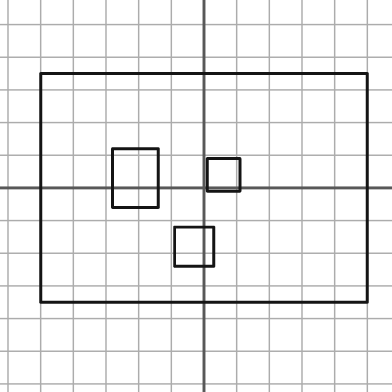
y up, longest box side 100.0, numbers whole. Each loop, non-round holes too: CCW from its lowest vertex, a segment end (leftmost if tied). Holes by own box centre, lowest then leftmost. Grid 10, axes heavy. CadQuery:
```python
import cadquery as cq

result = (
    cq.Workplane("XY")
    .moveTo(-50.0, -35.0)
    .lineTo(50.0, -35.0)
    .lineTo(50.0, 35.0)
    .lineTo(-50.0, 35.0)
    .close()
    .moveTo(-9.0, -24.0)
    .lineTo(3.0, -24.0)
    .lineTo(3.0, -12.0)
    .lineTo(-9.0, -12.0)
    .close()
    .moveTo(-28.0, -6.0)
    .lineTo(-14.0, -6.0)
    .lineTo(-14.0, 12.0)
    .lineTo(-28.0, 12.0)
    .close()
    .moveTo(1.0, -1.0)
    .lineTo(11.0, -1.0)
    .lineTo(11.0, 9.0)
    .lineTo(1.0, 9.0)
    .close()
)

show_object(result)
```